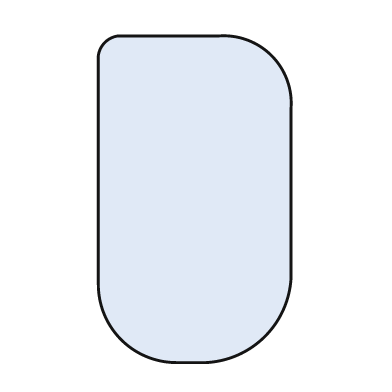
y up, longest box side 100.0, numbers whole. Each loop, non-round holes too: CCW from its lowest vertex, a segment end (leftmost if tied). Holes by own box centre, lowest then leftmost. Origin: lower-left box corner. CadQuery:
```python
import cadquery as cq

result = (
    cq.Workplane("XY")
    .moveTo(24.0, 0.0)
    .lineTo(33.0, 0.0)
    .threePointArc((51.0, 8.0), (59.0, 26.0))
    .lineTo(59.0, 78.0)
    .threePointArc((53.0, 94.0), (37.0, 100.0))
    .lineTo(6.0, 100.0)
    .threePointArc((2.0, 98.0), (0.0, 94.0))
    .lineTo(0.0, 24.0)
    .threePointArc((7.0, 7.0), (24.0, 0.0))
    .close()
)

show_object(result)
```